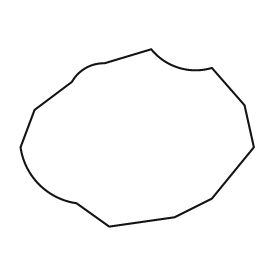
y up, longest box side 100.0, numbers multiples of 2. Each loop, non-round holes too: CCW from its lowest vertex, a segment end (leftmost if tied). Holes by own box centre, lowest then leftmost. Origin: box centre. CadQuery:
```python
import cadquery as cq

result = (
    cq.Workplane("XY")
    .moveTo(-12.0, -38.0)
    .lineTo(16.0, -34.0)
    .lineTo(32.0, -26.0)
    .lineTo(50.0, -4.0)
    .lineTo(46.0, 14.0)
    .lineTo(32.0, 30.0)
    .threePointArc((18.0, 30.0), (6.0, 38.0))
    .lineTo(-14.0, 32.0)
    .threePointArc((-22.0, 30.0), (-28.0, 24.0))
    .lineTo(-44.0, 12.0)
    .lineTo(-50.0, -4.0)
    .threePointArc((-42.0, -20.0), (-26.0, -28.0))
    .close()
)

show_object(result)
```